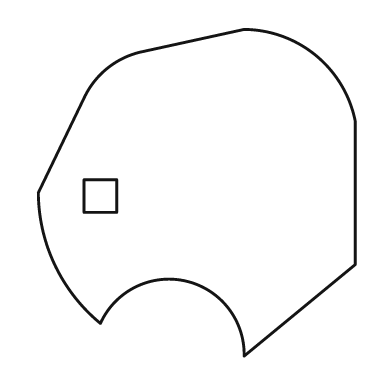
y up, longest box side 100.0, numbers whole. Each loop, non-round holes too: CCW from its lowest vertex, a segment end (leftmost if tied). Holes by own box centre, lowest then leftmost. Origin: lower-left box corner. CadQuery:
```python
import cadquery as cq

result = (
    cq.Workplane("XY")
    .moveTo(63.0, 0.0)
    .lineTo(97.0, 28.0)
    .lineTo(97.0, 72.0)
    .threePointArc((85.0, 92.0), (63.0, 100.0))
    .lineTo(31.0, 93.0)
    .threePointArc((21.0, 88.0), (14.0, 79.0))
    .lineTo(0.0, 50.0)
    .threePointArc((5.0, 28.0), (19.0, 10.0))
    .threePointArc((45.0, 23.0), (63.0, 0.0))
    .close()
    .moveTo(14.0, 44.0)
    .lineTo(24.0, 44.0)
    .lineTo(24.0, 54.0)
    .lineTo(14.0, 54.0)
    .close()
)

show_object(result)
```